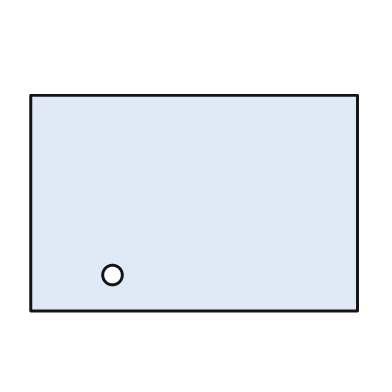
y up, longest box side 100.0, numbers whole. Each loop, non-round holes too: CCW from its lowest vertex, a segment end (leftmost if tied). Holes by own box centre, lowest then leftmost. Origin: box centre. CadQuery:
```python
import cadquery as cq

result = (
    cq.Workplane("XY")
    .moveTo(-50.0, -33.0)
    .lineTo(50.0, -33.0)
    .lineTo(50.0, 33.0)
    .lineTo(-50.0, 33.0)
    .close()
    .moveTo(-25.0, -22.0)
    .circle(3.0)
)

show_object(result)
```